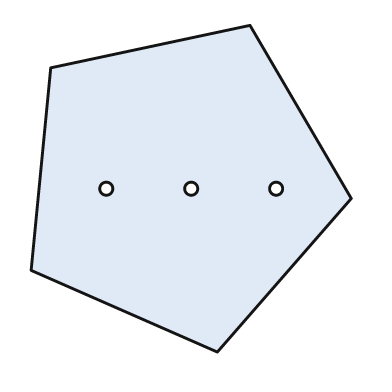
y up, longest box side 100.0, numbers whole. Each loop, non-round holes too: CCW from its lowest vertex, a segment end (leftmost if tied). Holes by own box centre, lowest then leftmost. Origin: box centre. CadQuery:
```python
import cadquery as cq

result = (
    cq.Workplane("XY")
    .moveTo(8.0, -50.0)
    .lineTo(49.0, -3.0)
    .lineTo(18.0, 50.0)
    .lineTo(-43.0, 37.0)
    .lineTo(-49.0, -25.0)
    .close()
    .moveTo(-26.0, 0.0)
    .circle(2.0)
    .moveTo(0.0, 0.0)
    .circle(2.0)
    .moveTo(26.0, 0.0)
    .circle(2.0)
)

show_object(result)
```